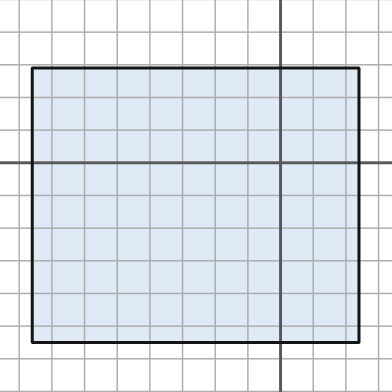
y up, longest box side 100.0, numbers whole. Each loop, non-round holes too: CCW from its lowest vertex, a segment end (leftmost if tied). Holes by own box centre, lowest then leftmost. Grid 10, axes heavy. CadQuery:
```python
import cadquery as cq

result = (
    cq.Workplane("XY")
    .moveTo(-76.0, -55.0)
    .lineTo(24.0, -55.0)
    .lineTo(24.0, 29.0)
    .lineTo(-76.0, 29.0)
    .close()
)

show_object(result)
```